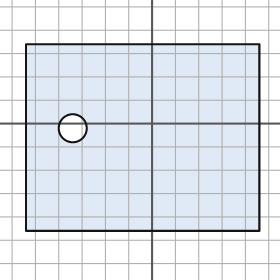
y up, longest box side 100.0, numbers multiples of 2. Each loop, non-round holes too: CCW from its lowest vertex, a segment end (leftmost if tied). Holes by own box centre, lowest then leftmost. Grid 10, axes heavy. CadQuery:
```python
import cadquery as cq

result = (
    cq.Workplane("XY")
    .moveTo(-54.0, -46.0)
    .lineTo(46.0, -46.0)
    .lineTo(46.0, 34.0)
    .lineTo(-54.0, 34.0)
    .close()
    .moveTo(-34.0, -2.0)
    .circle(6.0)
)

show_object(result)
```